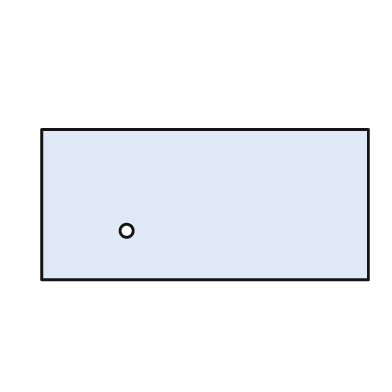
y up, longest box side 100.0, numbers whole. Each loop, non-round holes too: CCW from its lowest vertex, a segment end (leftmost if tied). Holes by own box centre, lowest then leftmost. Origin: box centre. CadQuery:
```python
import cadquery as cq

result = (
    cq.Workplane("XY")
    .moveTo(-50.0, -23.0)
    .lineTo(50.0, -23.0)
    .lineTo(50.0, 23.0)
    .lineTo(-50.0, 23.0)
    .close()
    .moveTo(-24.0, -8.0)
    .circle(2.0)
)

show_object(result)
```